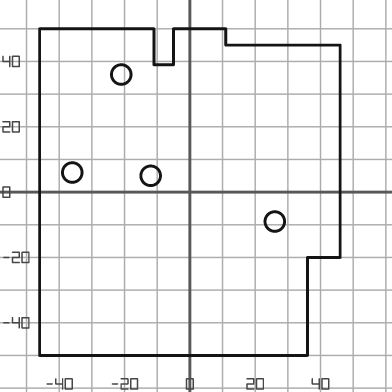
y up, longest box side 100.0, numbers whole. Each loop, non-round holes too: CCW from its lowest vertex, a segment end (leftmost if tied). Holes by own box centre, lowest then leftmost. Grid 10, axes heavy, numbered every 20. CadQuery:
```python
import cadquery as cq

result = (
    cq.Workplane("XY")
    .moveTo(-46.0, -50.0)
    .lineTo(36.0, -50.0)
    .lineTo(36.0, -20.0)
    .lineTo(46.0, -20.0)
    .lineTo(46.0, 45.0)
    .lineTo(11.0, 45.0)
    .lineTo(11.0, 50.0)
    .lineTo(-5.0, 50.0)
    .lineTo(-5.0, 39.0)
    .lineTo(-11.0, 39.0)
    .lineTo(-11.0, 50.0)
    .lineTo(-46.0, 50.0)
    .close()
    .moveTo(26.0, -9.0)
    .circle(3.0)
    .moveTo(-12.0, 5.0)
    .circle(3.0)
    .moveTo(-36.0, 6.0)
    .circle(3.0)
    .moveTo(-21.0, 36.0)
    .circle(3.0)
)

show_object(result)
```